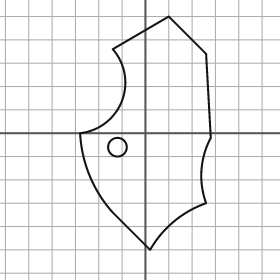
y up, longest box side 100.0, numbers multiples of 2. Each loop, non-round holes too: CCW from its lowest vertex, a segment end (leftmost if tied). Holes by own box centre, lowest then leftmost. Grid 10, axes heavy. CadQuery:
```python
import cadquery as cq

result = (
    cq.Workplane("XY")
    .moveTo(2.0, -50.0)
    .threePointArc((12.0, -38.0), (26.0, -30.0))
    .threePointArc((24.0, -16.0), (28.0, -2.0))
    .lineTo(26.0, 34.0)
    .lineTo(10.0, 50.0)
    .lineTo(-14.0, 36.0)
    .threePointArc((-10.0, 14.0), (-28.0, 0.0))
    .threePointArc((-24.0, -18.0), (-14.0, -34.0))
    .close()
    .moveTo(-12.0, -6.0)
    .circle(4.0)
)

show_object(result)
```